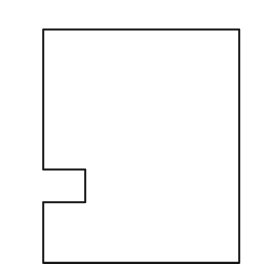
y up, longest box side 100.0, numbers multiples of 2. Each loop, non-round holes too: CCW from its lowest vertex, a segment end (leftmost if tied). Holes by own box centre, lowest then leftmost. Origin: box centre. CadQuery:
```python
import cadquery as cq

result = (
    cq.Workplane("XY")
    .moveTo(-42.0, -50.0)
    .lineTo(42.0, -50.0)
    .lineTo(42.0, 50.0)
    .lineTo(-42.0, 50.0)
    .lineTo(-42.0, -10.0)
    .lineTo(-24.0, -10.0)
    .lineTo(-24.0, -24.0)
    .lineTo(-42.0, -24.0)
    .close()
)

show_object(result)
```